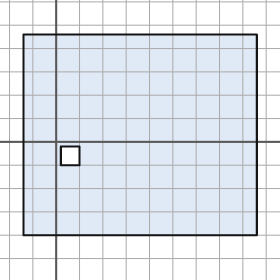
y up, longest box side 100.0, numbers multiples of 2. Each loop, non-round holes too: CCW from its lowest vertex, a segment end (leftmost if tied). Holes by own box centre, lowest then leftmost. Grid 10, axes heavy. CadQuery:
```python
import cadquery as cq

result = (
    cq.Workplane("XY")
    .moveTo(-14.0, -40.0)
    .lineTo(86.0, -40.0)
    .lineTo(86.0, 46.0)
    .lineTo(-14.0, 46.0)
    .close()
    .moveTo(2.0, -10.0)
    .lineTo(10.0, -10.0)
    .lineTo(10.0, -2.0)
    .lineTo(2.0, -2.0)
    .close()
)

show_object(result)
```